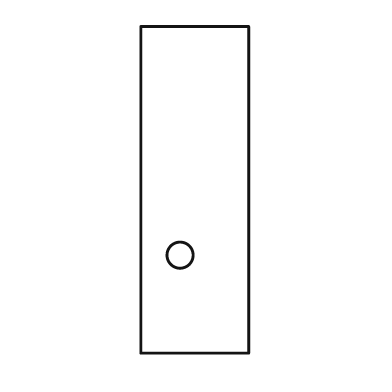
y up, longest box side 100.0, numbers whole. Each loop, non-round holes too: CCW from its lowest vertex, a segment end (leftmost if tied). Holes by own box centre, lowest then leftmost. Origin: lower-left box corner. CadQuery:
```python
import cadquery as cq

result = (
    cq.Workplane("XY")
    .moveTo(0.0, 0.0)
    .lineTo(33.0, 0.0)
    .lineTo(33.0, 100.0)
    .lineTo(0.0, 100.0)
    .close()
    .moveTo(12.0, 30.0)
    .circle(4.0)
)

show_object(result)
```